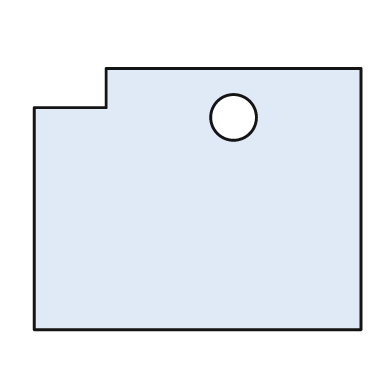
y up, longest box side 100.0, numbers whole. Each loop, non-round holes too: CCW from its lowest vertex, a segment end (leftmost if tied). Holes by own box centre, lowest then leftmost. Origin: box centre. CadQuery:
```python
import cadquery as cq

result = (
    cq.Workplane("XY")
    .moveTo(-50.0, -40.0)
    .lineTo(50.0, -40.0)
    .lineTo(50.0, 40.0)
    .lineTo(-28.0, 40.0)
    .lineTo(-28.0, 28.0)
    .lineTo(-50.0, 28.0)
    .close()
    .moveTo(11.0, 25.0)
    .circle(7.0)
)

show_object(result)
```